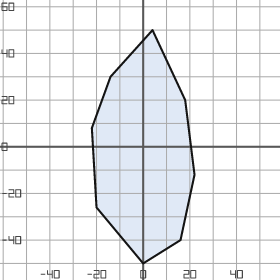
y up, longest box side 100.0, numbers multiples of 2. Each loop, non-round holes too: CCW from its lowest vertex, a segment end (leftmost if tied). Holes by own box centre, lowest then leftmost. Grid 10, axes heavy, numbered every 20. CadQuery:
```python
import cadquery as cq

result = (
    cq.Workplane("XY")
    .moveTo(0.0, -50.0)
    .lineTo(16.0, -40.0)
    .lineTo(22.0, -12.0)
    .lineTo(18.0, 20.0)
    .lineTo(4.0, 50.0)
    .lineTo(-14.0, 30.0)
    .lineTo(-22.0, 8.0)
    .lineTo(-20.0, -26.0)
    .close()
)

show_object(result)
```